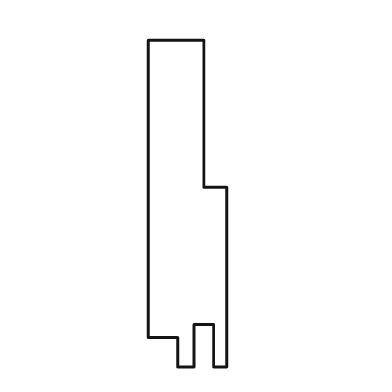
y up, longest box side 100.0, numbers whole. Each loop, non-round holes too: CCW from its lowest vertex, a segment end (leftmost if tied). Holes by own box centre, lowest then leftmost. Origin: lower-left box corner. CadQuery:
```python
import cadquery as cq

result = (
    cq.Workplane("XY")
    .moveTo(9.0, 0.0)
    .lineTo(14.0, 0.0)
    .lineTo(14.0, 13.0)
    .lineTo(20.0, 13.0)
    .lineTo(20.0, 0.0)
    .lineTo(24.0, 0.0)
    .lineTo(24.0, 55.0)
    .lineTo(17.0, 55.0)
    .lineTo(17.0, 100.0)
    .lineTo(0.0, 100.0)
    .lineTo(0.0, 9.0)
    .lineTo(9.0, 9.0)
    .close()
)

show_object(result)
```